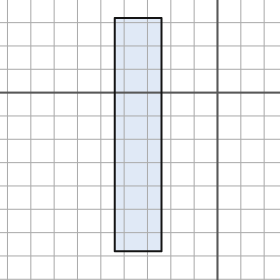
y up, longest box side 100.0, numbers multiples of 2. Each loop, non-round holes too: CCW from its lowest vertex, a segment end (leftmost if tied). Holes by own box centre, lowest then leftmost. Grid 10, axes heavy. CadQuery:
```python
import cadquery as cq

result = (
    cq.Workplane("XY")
    .moveTo(-44.0, -68.0)
    .lineTo(-24.0, -68.0)
    .lineTo(-24.0, 32.0)
    .lineTo(-44.0, 32.0)
    .close()
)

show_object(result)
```